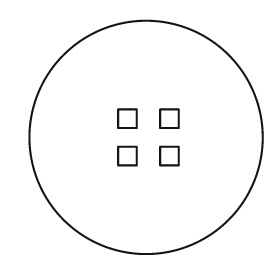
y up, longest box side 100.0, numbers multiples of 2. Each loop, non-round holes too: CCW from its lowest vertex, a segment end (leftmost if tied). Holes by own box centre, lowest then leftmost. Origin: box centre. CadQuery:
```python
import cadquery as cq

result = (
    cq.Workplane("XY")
    .moveTo(0.0, 0.0)
    .circle(50.0)
    .moveTo(-12.0, -12.0)
    .lineTo(-4.0, -12.0)
    .lineTo(-4.0, -4.0)
    .lineTo(-12.0, -4.0)
    .close()
    .moveTo(6.0, -12.0)
    .lineTo(14.0, -12.0)
    .lineTo(14.0, -4.0)
    .lineTo(6.0, -4.0)
    .close()
    .moveTo(-12.0, 4.0)
    .lineTo(-4.0, 4.0)
    .lineTo(-4.0, 12.0)
    .lineTo(-12.0, 12.0)
    .close()
    .moveTo(6.0, 4.0)
    .lineTo(14.0, 4.0)
    .lineTo(14.0, 12.0)
    .lineTo(6.0, 12.0)
    .close()
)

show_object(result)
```